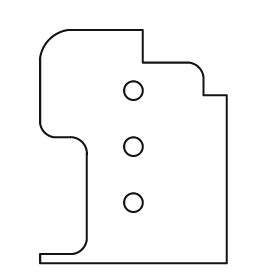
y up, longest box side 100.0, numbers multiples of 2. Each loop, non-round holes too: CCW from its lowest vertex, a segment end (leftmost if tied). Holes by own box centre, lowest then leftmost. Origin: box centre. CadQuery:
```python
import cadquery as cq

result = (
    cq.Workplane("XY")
    .moveTo(-40.0, -50.0)
    .lineTo(40.0, -50.0)
    .lineTo(40.0, 22.0)
    .lineTo(30.0, 22.0)
    .lineTo(30.0, 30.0)
    .threePointArc((28.0, 34.0), (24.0, 36.0))
    .lineTo(4.0, 36.0)
    .lineTo(4.0, 50.0)
    .lineTo(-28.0, 50.0)
    .threePointArc((-36.0, 46.0), (-40.0, 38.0))
    .lineTo(-40.0, 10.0)
    .threePointArc((-38.0, 6.0), (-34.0, 4.0))
    .lineTo(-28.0, 4.0)
    .threePointArc((-22.0, 2.0), (-20.0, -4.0))
    .lineTo(-20.0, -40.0)
    .threePointArc((-22.0, -44.0), (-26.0, -46.0))
    .lineTo(-40.0, -46.0)
    .close()
    .moveTo(0.0, -24.0)
    .circle(4.0)
    .moveTo(0.0, 0.0)
    .circle(4.0)
    .moveTo(0.0, 24.0)
    .circle(4.0)
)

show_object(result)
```